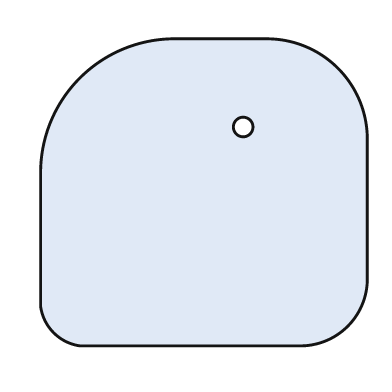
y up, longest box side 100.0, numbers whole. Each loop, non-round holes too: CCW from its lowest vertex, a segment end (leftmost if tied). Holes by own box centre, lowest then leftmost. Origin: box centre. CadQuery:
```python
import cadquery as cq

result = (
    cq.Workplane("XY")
    .moveTo(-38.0, -47.0)
    .lineTo(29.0, -47.0)
    .threePointArc((44.0, -41.0), (50.0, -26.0))
    .lineTo(50.0, 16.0)
    .threePointArc((41.0, 38.0), (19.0, 47.0))
    .lineTo(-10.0, 47.0)
    .threePointArc((-38.0, 35.0), (-50.0, 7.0))
    .lineTo(-50.0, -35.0)
    .threePointArc((-46.0, -43.0), (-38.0, -47.0))
    .close()
    .moveTo(12.0, 20.0)
    .circle(3.0)
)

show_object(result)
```